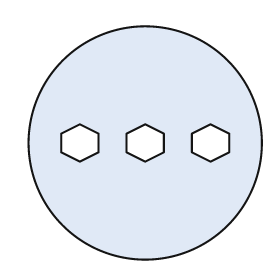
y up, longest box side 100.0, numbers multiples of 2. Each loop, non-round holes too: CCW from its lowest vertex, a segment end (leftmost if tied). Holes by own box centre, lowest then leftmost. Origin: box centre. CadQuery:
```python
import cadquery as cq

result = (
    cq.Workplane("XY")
    .moveTo(0.0, 0.0)
    .circle(50.0)
    .moveTo(-28.0, -8.0)
    .lineTo(-20.0, -4.0)
    .lineTo(-20.0, 4.0)
    .lineTo(-28.0, 8.0)
    .lineTo(-36.0, 4.0)
    .lineTo(-36.0, -4.0)
    .close()
    .moveTo(0.0, -8.0)
    .lineTo(8.0, -4.0)
    .lineTo(8.0, 4.0)
    .lineTo(0.0, 8.0)
    .lineTo(-8.0, 4.0)
    .lineTo(-8.0, -4.0)
    .close()
    .moveTo(28.0, -8.0)
    .lineTo(36.0, -4.0)
    .lineTo(36.0, 4.0)
    .lineTo(28.0, 8.0)
    .lineTo(20.0, 4.0)
    .lineTo(20.0, -4.0)
    .close()
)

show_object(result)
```